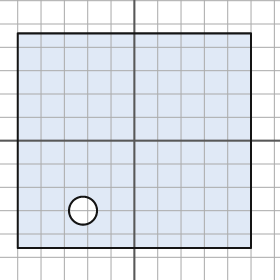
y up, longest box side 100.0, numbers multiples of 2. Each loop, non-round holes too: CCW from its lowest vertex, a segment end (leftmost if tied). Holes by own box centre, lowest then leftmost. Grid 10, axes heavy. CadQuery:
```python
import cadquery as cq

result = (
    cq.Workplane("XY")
    .moveTo(-50.0, -46.0)
    .lineTo(50.0, -46.0)
    .lineTo(50.0, 46.0)
    .lineTo(-50.0, 46.0)
    .close()
    .moveTo(-22.0, -30.0)
    .circle(6.0)
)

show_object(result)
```